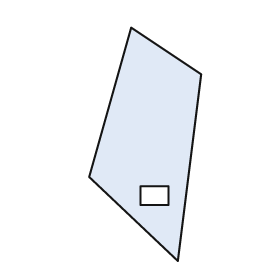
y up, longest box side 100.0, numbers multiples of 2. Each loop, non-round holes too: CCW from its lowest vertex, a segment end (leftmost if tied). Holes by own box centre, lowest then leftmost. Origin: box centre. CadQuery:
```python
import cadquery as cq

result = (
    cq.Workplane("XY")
    .moveTo(14.0, -50.0)
    .lineTo(24.0, 30.0)
    .lineTo(-6.0, 50.0)
    .lineTo(-24.0, -14.0)
    .close()
    .moveTo(-2.0, -26.0)
    .lineTo(10.0, -26.0)
    .lineTo(10.0, -18.0)
    .lineTo(-2.0, -18.0)
    .close()
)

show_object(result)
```